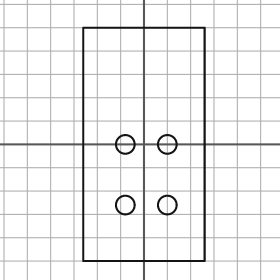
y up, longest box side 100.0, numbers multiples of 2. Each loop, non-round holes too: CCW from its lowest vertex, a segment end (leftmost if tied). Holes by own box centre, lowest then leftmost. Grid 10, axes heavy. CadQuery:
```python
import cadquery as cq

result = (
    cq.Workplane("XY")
    .moveTo(-26.0, -50.0)
    .lineTo(26.0, -50.0)
    .lineTo(26.0, 50.0)
    .lineTo(-26.0, 50.0)
    .close()
    .moveTo(-8.0, -26.0)
    .circle(4.0)
    .moveTo(10.0, -26.0)
    .circle(4.0)
    .moveTo(-8.0, 0.0)
    .circle(4.0)
    .moveTo(10.0, 0.0)
    .circle(4.0)
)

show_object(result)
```